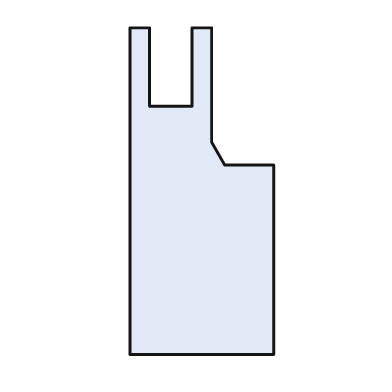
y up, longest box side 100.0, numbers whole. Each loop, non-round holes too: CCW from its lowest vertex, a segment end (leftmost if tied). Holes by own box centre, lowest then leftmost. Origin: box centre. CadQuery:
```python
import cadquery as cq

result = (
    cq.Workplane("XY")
    .moveTo(-22.0, -50.0)
    .lineTo(22.0, -50.0)
    .lineTo(22.0, 8.0)
    .lineTo(7.0, 8.0)
    .lineTo(3.0, 15.0)
    .lineTo(3.0, 50.0)
    .lineTo(-3.0, 50.0)
    .lineTo(-3.0, 26.0)
    .lineTo(-16.0, 26.0)
    .lineTo(-16.0, 50.0)
    .lineTo(-22.0, 50.0)
    .close()
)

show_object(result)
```